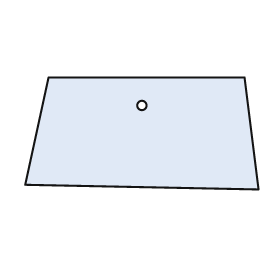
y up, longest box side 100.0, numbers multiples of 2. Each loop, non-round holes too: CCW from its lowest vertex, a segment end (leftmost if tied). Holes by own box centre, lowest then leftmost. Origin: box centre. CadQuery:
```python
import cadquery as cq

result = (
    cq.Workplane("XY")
    .moveTo(50.0, -24.0)
    .lineTo(44.0, 24.0)
    .lineTo(-40.0, 24.0)
    .lineTo(-50.0, -22.0)
    .close()
    .moveTo(0.0, 12.0)
    .circle(2.0)
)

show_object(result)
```